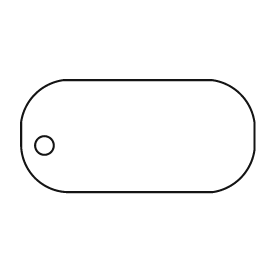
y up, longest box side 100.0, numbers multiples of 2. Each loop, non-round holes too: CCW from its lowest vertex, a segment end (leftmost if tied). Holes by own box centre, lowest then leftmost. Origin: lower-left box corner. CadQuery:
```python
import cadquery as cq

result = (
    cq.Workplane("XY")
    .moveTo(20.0, 0.0)
    .lineTo(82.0, 0.0)
    .threePointArc((94.0, 6.0), (100.0, 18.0))
    .lineTo(100.0, 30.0)
    .threePointArc((94.0, 42.0), (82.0, 48.0))
    .lineTo(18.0, 48.0)
    .threePointArc((6.0, 42.0), (0.0, 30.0))
    .lineTo(0.0, 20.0)
    .threePointArc((6.0, 6.0), (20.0, 0.0))
    .close()
    .moveTo(10.0, 20.0)
    .circle(4.0)
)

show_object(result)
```